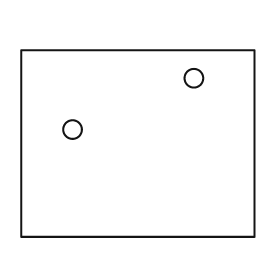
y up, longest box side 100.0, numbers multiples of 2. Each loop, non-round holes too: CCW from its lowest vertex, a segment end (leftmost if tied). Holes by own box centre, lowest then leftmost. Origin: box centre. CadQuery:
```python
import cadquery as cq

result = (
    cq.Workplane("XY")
    .moveTo(-50.0, -40.0)
    .lineTo(50.0, -40.0)
    .lineTo(50.0, 40.0)
    .lineTo(-50.0, 40.0)
    .close()
    .moveTo(-28.0, 6.0)
    .circle(4.0)
    .moveTo(24.0, 28.0)
    .circle(4.0)
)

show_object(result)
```